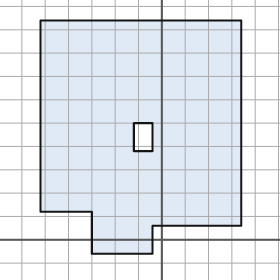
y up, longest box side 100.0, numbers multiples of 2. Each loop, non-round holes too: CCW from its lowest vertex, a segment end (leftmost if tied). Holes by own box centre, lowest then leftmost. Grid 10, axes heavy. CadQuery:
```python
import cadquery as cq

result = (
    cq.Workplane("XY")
    .moveTo(-30.0, -6.0)
    .lineTo(-4.0, -6.0)
    .lineTo(-4.0, 6.0)
    .lineTo(34.0, 6.0)
    .lineTo(34.0, 94.0)
    .lineTo(-52.0, 94.0)
    .lineTo(-52.0, 12.0)
    .lineTo(-30.0, 12.0)
    .close()
    .moveTo(-12.0, 38.0)
    .lineTo(-4.0, 38.0)
    .lineTo(-4.0, 50.0)
    .lineTo(-12.0, 50.0)
    .close()
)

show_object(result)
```